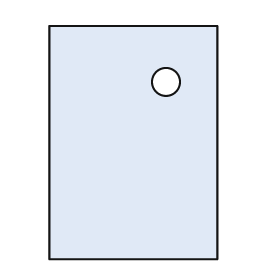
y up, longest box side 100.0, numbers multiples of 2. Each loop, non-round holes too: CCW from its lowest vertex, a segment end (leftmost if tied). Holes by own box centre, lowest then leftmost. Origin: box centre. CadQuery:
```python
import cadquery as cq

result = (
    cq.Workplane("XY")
    .moveTo(-36.0, -50.0)
    .lineTo(36.0, -50.0)
    .lineTo(36.0, 50.0)
    .lineTo(-36.0, 50.0)
    .close()
    .moveTo(14.0, 26.0)
    .circle(6.0)
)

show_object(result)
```